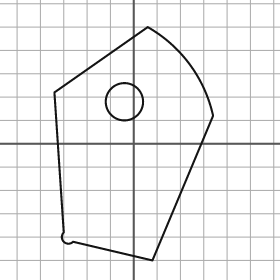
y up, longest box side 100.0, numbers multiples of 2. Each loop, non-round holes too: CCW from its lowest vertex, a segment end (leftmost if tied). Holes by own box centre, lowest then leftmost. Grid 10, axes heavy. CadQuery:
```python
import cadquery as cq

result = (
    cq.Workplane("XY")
    .moveTo(8.0, -50.0)
    .lineTo(34.0, 12.0)
    .threePointArc((24.0, 34.0), (6.0, 50.0))
    .lineTo(-34.0, 22.0)
    .lineTo(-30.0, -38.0)
    .threePointArc((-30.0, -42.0), (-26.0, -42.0))
    .close()
    .moveTo(-4.0, 18.0)
    .circle(8.0)
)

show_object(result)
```